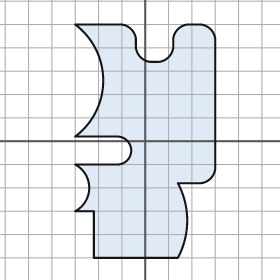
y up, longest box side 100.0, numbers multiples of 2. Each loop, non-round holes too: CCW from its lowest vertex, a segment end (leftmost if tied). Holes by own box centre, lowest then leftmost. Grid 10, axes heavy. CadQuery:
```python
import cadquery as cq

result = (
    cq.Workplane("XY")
    .moveTo(-22.0, -50.0)
    .lineTo(14.0, -50.0)
    .threePointArc((18.0, -34.0), (14.0, -18.0))
    .lineTo(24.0, -18.0)
    .threePointArc((28.0, -16.0), (30.0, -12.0))
    .lineTo(30.0, 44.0)
    .threePointArc((28.0, 48.0), (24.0, 50.0))
    .lineTo(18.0, 50.0)
    .threePointArc((14.0, 48.0), (12.0, 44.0))
    .lineTo(12.0, 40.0)
    .threePointArc((10.0, 36.0), (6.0, 34.0))
    .lineTo(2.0, 34.0)
    .threePointArc((-2.0, 36.0), (-4.0, 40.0))
    .lineTo(-4.0, 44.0)
    .threePointArc((-6.0, 48.0), (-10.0, 50.0))
    .lineTo(-30.0, 50.0)
    .threePointArc((-18.0, 26.0), (-30.0, 2.0))
    .lineTo(-12.0, 2.0)
    .threePointArc((-6.0, -4.0), (-12.0, -10.0))
    .lineTo(-30.0, -10.0)
    .threePointArc((-24.0, -20.0), (-30.0, -30.0))
    .lineTo(-22.0, -30.0)
    .close()
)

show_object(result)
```